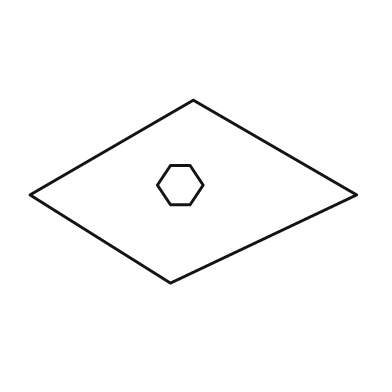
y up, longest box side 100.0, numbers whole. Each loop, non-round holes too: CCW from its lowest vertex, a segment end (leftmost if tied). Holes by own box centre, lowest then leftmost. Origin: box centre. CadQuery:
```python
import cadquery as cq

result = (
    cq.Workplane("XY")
    .moveTo(-7.0, -28.0)
    .lineTo(50.0, -1.0)
    .lineTo(0.0, 28.0)
    .lineTo(-50.0, -1.0)
    .close()
    .moveTo(-7.0, -4.0)
    .lineTo(-1.0, -4.0)
    .lineTo(3.0, 2.0)
    .lineTo(-1.0, 8.0)
    .lineTo(-7.0, 8.0)
    .lineTo(-11.0, 2.0)
    .close()
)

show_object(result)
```